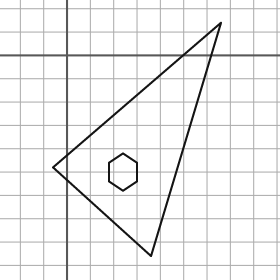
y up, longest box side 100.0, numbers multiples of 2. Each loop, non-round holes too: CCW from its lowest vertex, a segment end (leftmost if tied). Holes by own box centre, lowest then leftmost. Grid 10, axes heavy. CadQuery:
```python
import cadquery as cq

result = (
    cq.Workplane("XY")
    .moveTo(36.0, -86.0)
    .lineTo(66.0, 14.0)
    .lineTo(-6.0, -48.0)
    .close()
    .moveTo(24.0, -58.0)
    .lineTo(30.0, -54.0)
    .lineTo(30.0, -46.0)
    .lineTo(24.0, -42.0)
    .lineTo(18.0, -46.0)
    .lineTo(18.0, -54.0)
    .close()
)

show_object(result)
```